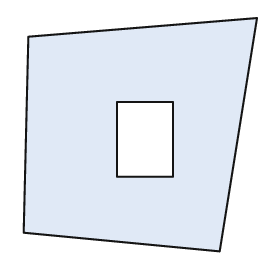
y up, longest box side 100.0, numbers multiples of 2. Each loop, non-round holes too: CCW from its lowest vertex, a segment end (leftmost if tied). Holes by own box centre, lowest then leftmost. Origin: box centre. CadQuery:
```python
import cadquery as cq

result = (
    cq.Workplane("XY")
    .moveTo(34.0, -50.0)
    .lineTo(50.0, 50.0)
    .lineTo(-48.0, 42.0)
    .lineTo(-50.0, -42.0)
    .close()
    .moveTo(-10.0, -18.0)
    .lineTo(14.0, -18.0)
    .lineTo(14.0, 14.0)
    .lineTo(-10.0, 14.0)
    .close()
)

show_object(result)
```